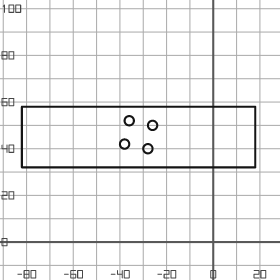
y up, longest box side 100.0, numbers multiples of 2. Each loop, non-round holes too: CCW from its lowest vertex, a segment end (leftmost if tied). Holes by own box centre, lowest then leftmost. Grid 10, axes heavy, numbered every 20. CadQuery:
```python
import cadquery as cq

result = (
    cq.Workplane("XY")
    .moveTo(-82.0, 32.0)
    .lineTo(18.0, 32.0)
    .lineTo(18.0, 58.0)
    .lineTo(-82.0, 58.0)
    .close()
    .moveTo(-28.0, 40.0)
    .circle(2.0)
    .moveTo(-38.0, 42.0)
    .circle(2.0)
    .moveTo(-26.0, 50.0)
    .circle(2.0)
    .moveTo(-36.0, 52.0)
    .circle(2.0)
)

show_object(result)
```